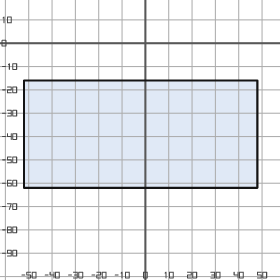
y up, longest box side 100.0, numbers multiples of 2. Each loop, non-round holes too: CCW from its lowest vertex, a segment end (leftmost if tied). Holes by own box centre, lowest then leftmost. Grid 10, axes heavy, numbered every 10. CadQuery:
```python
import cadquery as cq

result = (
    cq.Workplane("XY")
    .moveTo(-52.0, -62.0)
    .lineTo(48.0, -62.0)
    .lineTo(48.0, -16.0)
    .lineTo(-52.0, -16.0)
    .close()
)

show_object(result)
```